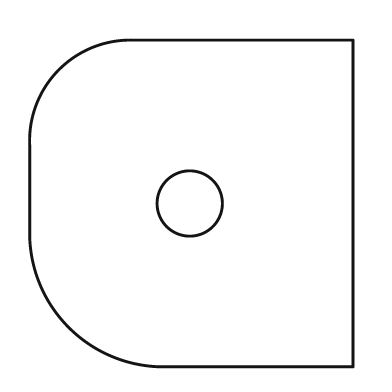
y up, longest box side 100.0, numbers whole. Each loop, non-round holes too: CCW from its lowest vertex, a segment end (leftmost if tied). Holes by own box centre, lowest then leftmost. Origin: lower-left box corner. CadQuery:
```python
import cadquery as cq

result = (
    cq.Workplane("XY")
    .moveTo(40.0, 0.0)
    .lineTo(99.0, 0.0)
    .lineTo(99.0, 100.0)
    .lineTo(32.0, 100.0)
    .threePointArc((9.0, 91.0), (0.0, 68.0))
    .lineTo(0.0, 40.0)
    .threePointArc((12.0, 12.0), (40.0, 0.0))
    .close()
    .moveTo(49.0, 50.0)
    .circle(10.0)
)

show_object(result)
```